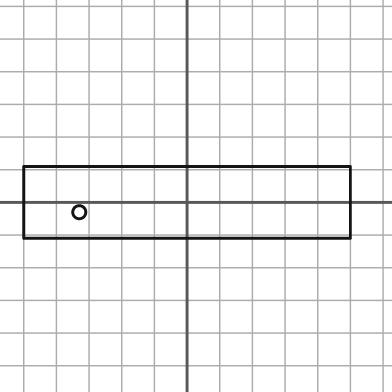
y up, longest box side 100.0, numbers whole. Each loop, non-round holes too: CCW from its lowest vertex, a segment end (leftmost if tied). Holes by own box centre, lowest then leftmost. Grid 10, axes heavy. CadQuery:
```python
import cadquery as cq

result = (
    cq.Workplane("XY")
    .moveTo(-50.0, -11.0)
    .lineTo(50.0, -11.0)
    .lineTo(50.0, 11.0)
    .lineTo(-50.0, 11.0)
    .close()
    .moveTo(-33.0, -3.0)
    .circle(2.0)
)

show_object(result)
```